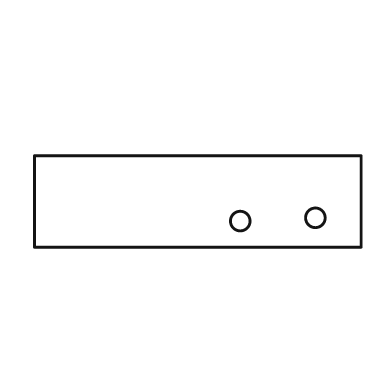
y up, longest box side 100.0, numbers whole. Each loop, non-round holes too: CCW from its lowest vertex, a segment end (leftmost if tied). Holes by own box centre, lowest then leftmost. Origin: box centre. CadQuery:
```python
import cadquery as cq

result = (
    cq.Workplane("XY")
    .moveTo(-50.0, -14.0)
    .lineTo(50.0, -14.0)
    .lineTo(50.0, 14.0)
    .lineTo(-50.0, 14.0)
    .close()
    .moveTo(13.0, -6.0)
    .circle(3.0)
    .moveTo(36.0, -5.0)
    .circle(3.0)
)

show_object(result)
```